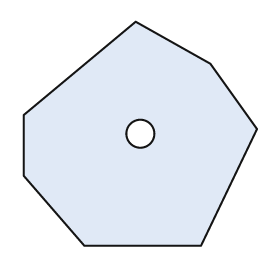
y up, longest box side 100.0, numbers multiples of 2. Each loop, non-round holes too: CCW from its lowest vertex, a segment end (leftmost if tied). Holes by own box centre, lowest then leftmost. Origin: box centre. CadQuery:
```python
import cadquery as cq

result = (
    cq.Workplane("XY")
    .moveTo(-24.0, -48.0)
    .lineTo(26.0, -48.0)
    .lineTo(50.0, 2.0)
    .lineTo(30.0, 30.0)
    .lineTo(-2.0, 48.0)
    .lineTo(-50.0, 8.0)
    .lineTo(-50.0, -18.0)
    .close()
    .moveTo(0.0, 0.0)
    .circle(6.0)
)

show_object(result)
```